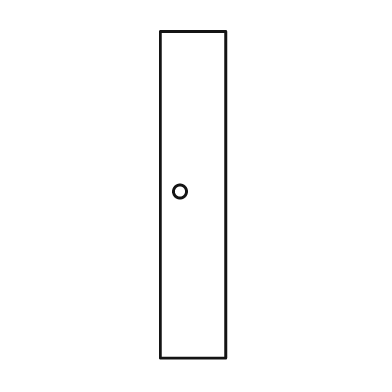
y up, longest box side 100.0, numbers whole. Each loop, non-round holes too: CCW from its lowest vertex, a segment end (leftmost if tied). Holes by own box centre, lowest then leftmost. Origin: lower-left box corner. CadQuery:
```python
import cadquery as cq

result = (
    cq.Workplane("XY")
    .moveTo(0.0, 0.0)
    .lineTo(20.0, 0.0)
    .lineTo(20.0, 100.0)
    .lineTo(0.0, 100.0)
    .close()
    .moveTo(6.0, 51.0)
    .circle(2.0)
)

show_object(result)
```